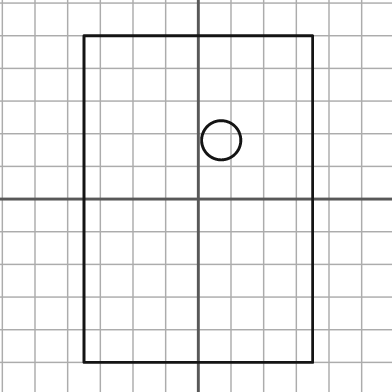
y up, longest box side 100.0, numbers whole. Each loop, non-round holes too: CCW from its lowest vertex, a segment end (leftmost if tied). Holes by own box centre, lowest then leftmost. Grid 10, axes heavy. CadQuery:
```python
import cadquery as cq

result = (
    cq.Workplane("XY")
    .moveTo(-35.0, -50.0)
    .lineTo(35.0, -50.0)
    .lineTo(35.0, 50.0)
    .lineTo(-35.0, 50.0)
    .close()
    .moveTo(7.0, 18.0)
    .circle(6.0)
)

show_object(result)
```